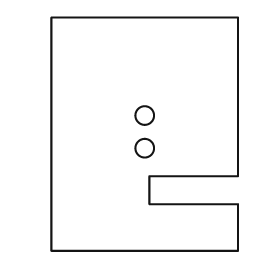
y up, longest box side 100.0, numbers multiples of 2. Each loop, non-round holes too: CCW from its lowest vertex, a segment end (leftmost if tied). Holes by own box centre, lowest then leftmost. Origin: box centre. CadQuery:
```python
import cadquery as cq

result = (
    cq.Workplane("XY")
    .moveTo(-40.0, -50.0)
    .lineTo(40.0, -50.0)
    .lineTo(40.0, -30.0)
    .lineTo(2.0, -30.0)
    .lineTo(2.0, -18.0)
    .lineTo(40.0, -18.0)
    .lineTo(40.0, 50.0)
    .lineTo(-40.0, 50.0)
    .close()
    .moveTo(0.0, -6.0)
    .circle(4.0)
    .moveTo(0.0, 8.0)
    .circle(4.0)
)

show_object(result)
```